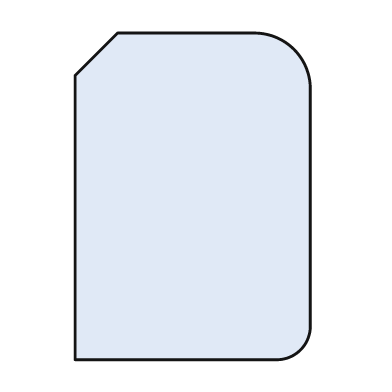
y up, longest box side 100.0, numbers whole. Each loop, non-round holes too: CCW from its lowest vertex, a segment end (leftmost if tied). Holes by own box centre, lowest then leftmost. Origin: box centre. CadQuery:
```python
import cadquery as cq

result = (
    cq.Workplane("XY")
    .moveTo(-36.0, -50.0)
    .lineTo(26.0, -50.0)
    .threePointArc((33.0, -47.0), (36.0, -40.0))
    .lineTo(36.0, 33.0)
    .threePointArc((31.0, 45.0), (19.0, 50.0))
    .lineTo(-23.0, 50.0)
    .lineTo(-36.0, 37.0)
    .close()
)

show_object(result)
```